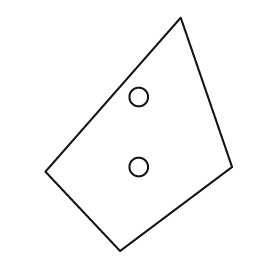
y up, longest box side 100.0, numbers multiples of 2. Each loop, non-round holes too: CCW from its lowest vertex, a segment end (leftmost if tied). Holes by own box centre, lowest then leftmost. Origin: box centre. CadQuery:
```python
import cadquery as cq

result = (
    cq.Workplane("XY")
    .moveTo(-8.0, -50.0)
    .lineTo(40.0, -14.0)
    .lineTo(18.0, 50.0)
    .lineTo(-40.0, -16.0)
    .close()
    .moveTo(0.0, -14.0)
    .circle(4.0)
    .moveTo(0.0, 16.0)
    .circle(4.0)
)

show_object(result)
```